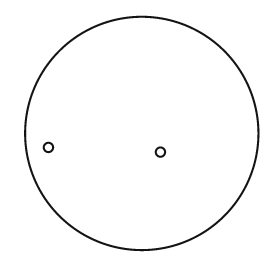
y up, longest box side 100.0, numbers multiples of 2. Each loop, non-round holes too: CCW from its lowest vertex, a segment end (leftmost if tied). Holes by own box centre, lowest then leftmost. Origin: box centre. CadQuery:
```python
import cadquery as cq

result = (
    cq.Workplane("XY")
    .moveTo(0.0, 0.0)
    .circle(50.0)
    .moveTo(8.0, -8.0)
    .circle(2.0)
    .moveTo(-40.0, -6.0)
    .circle(2.0)
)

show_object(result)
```